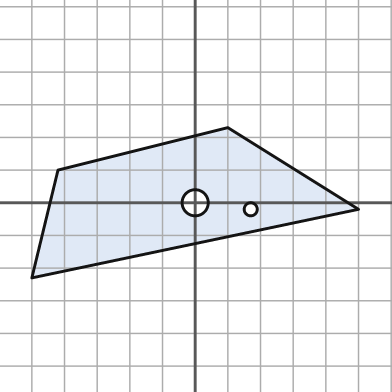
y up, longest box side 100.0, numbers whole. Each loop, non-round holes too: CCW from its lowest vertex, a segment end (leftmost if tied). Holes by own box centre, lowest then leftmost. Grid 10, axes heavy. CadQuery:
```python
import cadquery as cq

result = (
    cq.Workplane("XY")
    .moveTo(-50.0, -23.0)
    .lineTo(50.0, -2.0)
    .lineTo(10.0, 23.0)
    .lineTo(-42.0, 10.0)
    .close()
    .moveTo(17.0, -2.0)
    .circle(2.0)
    .moveTo(0.0, 0.0)
    .circle(4.0)
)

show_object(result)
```